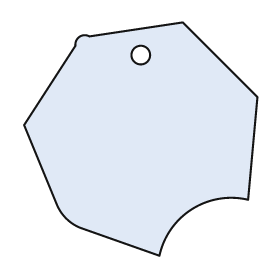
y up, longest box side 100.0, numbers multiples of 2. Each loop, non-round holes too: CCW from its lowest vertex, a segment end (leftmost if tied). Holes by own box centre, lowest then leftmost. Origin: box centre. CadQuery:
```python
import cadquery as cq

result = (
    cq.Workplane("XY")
    .moveTo(8.0, -50.0)
    .threePointArc((22.0, -30.0), (46.0, -26.0))
    .lineTo(50.0, 18.0)
    .lineTo(18.0, 50.0)
    .lineTo(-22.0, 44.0)
    .threePointArc((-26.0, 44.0), (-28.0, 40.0))
    .lineTo(-50.0, 6.0)
    .lineTo(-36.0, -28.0)
    .threePointArc((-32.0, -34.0), (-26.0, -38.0))
    .close()
    .moveTo(0.0, 36.0)
    .circle(4.0)
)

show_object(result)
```